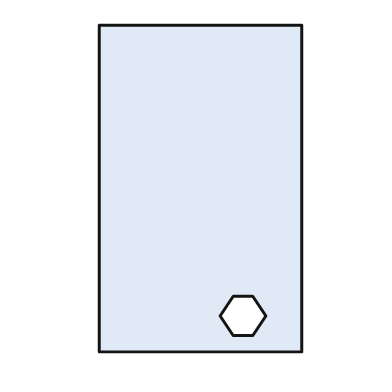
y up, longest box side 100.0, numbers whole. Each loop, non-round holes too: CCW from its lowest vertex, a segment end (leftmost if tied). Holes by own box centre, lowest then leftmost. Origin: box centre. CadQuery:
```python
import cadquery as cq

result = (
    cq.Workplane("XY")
    .moveTo(-31.0, -50.0)
    .lineTo(31.0, -50.0)
    .lineTo(31.0, 50.0)
    .lineTo(-31.0, 50.0)
    .close()
    .moveTo(10.0, -45.0)
    .lineTo(16.0, -45.0)
    .lineTo(20.0, -39.0)
    .lineTo(16.0, -33.0)
    .lineTo(10.0, -33.0)
    .lineTo(6.0, -39.0)
    .close()
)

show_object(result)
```